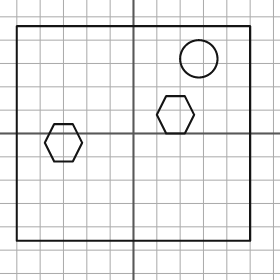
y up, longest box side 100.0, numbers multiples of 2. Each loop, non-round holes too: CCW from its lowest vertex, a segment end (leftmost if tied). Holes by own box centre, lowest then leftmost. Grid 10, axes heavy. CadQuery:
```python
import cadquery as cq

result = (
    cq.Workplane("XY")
    .moveTo(-50.0, -46.0)
    .lineTo(50.0, -46.0)
    .lineTo(50.0, 46.0)
    .lineTo(-50.0, 46.0)
    .close()
    .moveTo(-34.0, -12.0)
    .lineTo(-26.0, -12.0)
    .lineTo(-22.0, -4.0)
    .lineTo(-26.0, 4.0)
    .lineTo(-34.0, 4.0)
    .lineTo(-38.0, -4.0)
    .close()
    .moveTo(14.0, 0.0)
    .lineTo(22.0, 0.0)
    .lineTo(26.0, 8.0)
    .lineTo(22.0, 16.0)
    .lineTo(14.0, 16.0)
    .lineTo(10.0, 8.0)
    .close()
    .moveTo(28.0, 32.0)
    .circle(8.0)
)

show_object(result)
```